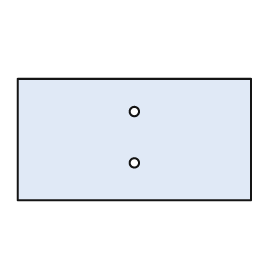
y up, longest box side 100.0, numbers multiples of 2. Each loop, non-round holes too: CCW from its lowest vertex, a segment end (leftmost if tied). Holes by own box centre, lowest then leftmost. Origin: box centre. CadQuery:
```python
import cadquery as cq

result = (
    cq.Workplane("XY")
    .moveTo(-50.0, -26.0)
    .lineTo(50.0, -26.0)
    .lineTo(50.0, 26.0)
    .lineTo(-50.0, 26.0)
    .close()
    .moveTo(0.0, -10.0)
    .circle(2.0)
    .moveTo(0.0, 12.0)
    .circle(2.0)
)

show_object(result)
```